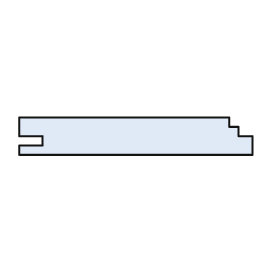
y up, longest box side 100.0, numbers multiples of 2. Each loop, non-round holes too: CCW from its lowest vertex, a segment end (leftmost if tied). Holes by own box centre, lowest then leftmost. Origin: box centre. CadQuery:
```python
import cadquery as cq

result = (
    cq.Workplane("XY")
    .moveTo(-50.0, -8.0)
    .lineTo(50.0, -8.0)
    .lineTo(50.0, 0.0)
    .lineTo(44.0, 0.0)
    .lineTo(44.0, 4.0)
    .lineTo(40.0, 4.0)
    .lineTo(40.0, 8.0)
    .lineTo(-50.0, 8.0)
    .lineTo(-50.0, 0.0)
    .lineTo(-40.0, 0.0)
    .lineTo(-40.0, -4.0)
    .lineTo(-50.0, -4.0)
    .close()
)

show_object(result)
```